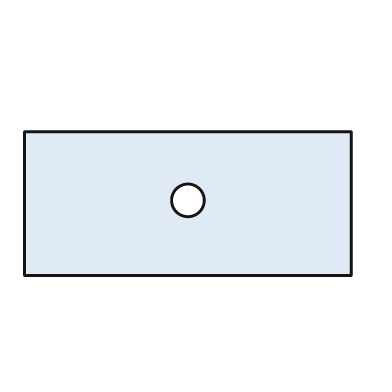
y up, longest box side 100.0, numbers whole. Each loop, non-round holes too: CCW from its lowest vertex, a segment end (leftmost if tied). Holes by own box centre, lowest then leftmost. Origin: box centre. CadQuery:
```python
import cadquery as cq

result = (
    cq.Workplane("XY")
    .moveTo(-50.0, -22.0)
    .lineTo(50.0, -22.0)
    .lineTo(50.0, 22.0)
    .lineTo(-50.0, 22.0)
    .close()
    .moveTo(0.0, 1.0)
    .circle(5.0)
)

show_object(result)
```